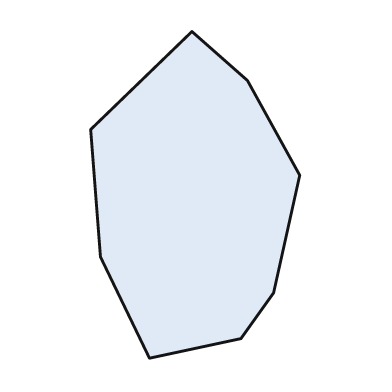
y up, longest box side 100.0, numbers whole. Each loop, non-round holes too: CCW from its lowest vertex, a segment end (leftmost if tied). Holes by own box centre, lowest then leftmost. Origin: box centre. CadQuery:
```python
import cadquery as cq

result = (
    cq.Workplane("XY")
    .moveTo(-14.0, -50.0)
    .lineTo(14.0, -44.0)
    .lineTo(24.0, -30.0)
    .lineTo(32.0, 6.0)
    .lineTo(16.0, 35.0)
    .lineTo(-1.0, 50.0)
    .lineTo(-32.0, 20.0)
    .lineTo(-29.0, -19.0)
    .close()
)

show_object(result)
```